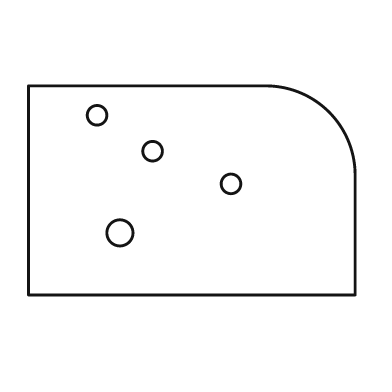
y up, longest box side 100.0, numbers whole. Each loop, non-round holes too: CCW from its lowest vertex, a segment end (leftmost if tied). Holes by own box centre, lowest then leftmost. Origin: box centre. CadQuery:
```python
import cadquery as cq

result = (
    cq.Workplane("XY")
    .moveTo(-50.0, -32.0)
    .lineTo(50.0, -32.0)
    .lineTo(50.0, 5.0)
    .threePointArc((42.0, 24.0), (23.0, 32.0))
    .lineTo(-50.0, 32.0)
    .close()
    .moveTo(-22.0, -13.0)
    .circle(4.0)
    .moveTo(12.0, 2.0)
    .circle(3.0)
    .moveTo(-12.0, 12.0)
    .circle(3.0)
    .moveTo(-29.0, 23.0)
    .circle(3.0)
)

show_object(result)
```